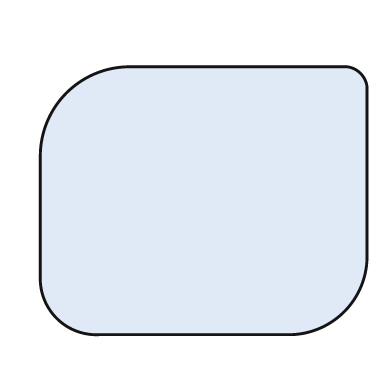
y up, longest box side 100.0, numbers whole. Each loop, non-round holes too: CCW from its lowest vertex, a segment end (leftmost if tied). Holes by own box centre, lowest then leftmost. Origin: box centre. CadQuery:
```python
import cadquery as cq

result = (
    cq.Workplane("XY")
    .moveTo(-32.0, -41.0)
    .lineTo(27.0, -41.0)
    .threePointArc((43.0, -34.0), (50.0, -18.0))
    .lineTo(50.0, 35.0)
    .threePointArc((48.0, 39.0), (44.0, 41.0))
    .lineTo(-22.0, 41.0)
    .threePointArc((-42.0, 33.0), (-50.0, 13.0))
    .lineTo(-50.0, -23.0)
    .threePointArc((-45.0, -36.0), (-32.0, -41.0))
    .close()
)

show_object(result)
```